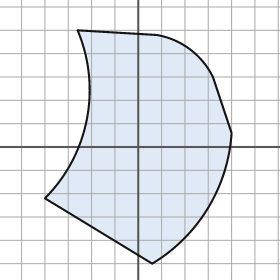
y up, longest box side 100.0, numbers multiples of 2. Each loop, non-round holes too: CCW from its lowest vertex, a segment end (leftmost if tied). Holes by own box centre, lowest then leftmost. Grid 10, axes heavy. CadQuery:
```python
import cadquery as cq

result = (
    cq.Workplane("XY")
    .moveTo(6.0, -50.0)
    .threePointArc((30.0, -26.0), (40.0, 6.0))
    .lineTo(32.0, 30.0)
    .threePointArc((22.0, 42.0), (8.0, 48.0))
    .lineTo(-26.0, 50.0)
    .threePointArc((-22.0, 12.0), (-40.0, -22.0))
    .close()
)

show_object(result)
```